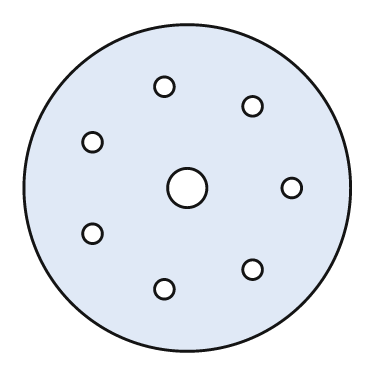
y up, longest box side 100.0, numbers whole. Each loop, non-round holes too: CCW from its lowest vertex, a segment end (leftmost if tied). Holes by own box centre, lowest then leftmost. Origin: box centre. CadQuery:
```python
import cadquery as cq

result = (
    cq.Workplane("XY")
    .moveTo(0.0, 0.0)
    .circle(50.0)
    .moveTo(-7.0, -31.0)
    .circle(3.0)
    .moveTo(20.0, -25.0)
    .circle(3.0)
    .moveTo(-29.0, -14.0)
    .circle(3.0)
    .moveTo(0.0, 0.0)
    .circle(6.0)
    .moveTo(32.0, 0.0)
    .circle(3.0)
    .moveTo(-29.0, 14.0)
    .circle(3.0)
    .moveTo(20.0, 25.0)
    .circle(3.0)
    .moveTo(-7.0, 31.0)
    .circle(3.0)
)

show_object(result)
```